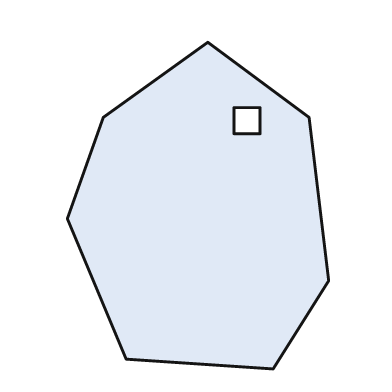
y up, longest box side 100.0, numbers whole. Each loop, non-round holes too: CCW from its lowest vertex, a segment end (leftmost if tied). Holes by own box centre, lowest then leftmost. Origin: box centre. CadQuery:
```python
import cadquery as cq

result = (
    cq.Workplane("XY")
    .moveTo(23.0, -50.0)
    .lineTo(40.0, -23.0)
    .lineTo(34.0, 27.0)
    .lineTo(3.0, 50.0)
    .lineTo(-29.0, 27.0)
    .lineTo(-40.0, -4.0)
    .lineTo(-22.0, -47.0)
    .close()
    .moveTo(11.0, 22.0)
    .lineTo(19.0, 22.0)
    .lineTo(19.0, 30.0)
    .lineTo(11.0, 30.0)
    .close()
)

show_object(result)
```